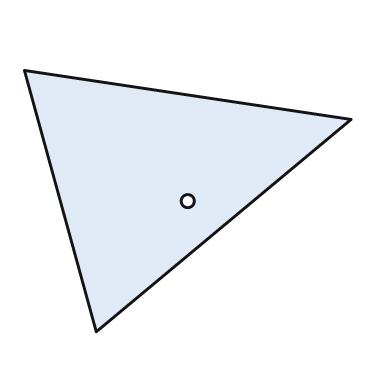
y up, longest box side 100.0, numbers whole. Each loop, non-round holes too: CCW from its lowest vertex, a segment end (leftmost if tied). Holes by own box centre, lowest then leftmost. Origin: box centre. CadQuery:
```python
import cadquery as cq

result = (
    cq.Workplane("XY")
    .moveTo(-28.0, -40.0)
    .lineTo(50.0, 25.0)
    .lineTo(-50.0, 40.0)
    .close()
    .moveTo(0.0, 0.0)
    .circle(2.0)
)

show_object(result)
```